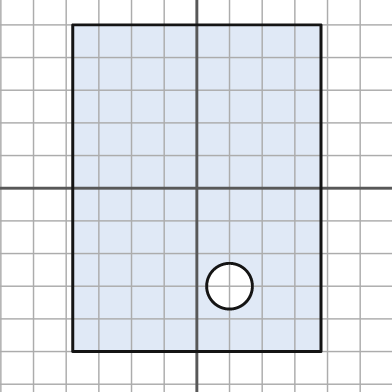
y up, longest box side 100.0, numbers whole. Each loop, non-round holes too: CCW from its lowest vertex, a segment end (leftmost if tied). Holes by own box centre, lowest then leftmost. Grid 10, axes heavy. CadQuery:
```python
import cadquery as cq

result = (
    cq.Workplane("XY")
    .moveTo(-38.0, -50.0)
    .lineTo(38.0, -50.0)
    .lineTo(38.0, 50.0)
    .lineTo(-38.0, 50.0)
    .close()
    .moveTo(10.0, -30.0)
    .circle(7.0)
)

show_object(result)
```